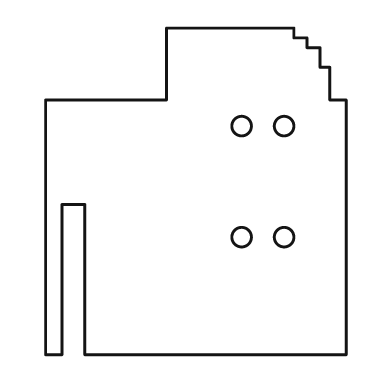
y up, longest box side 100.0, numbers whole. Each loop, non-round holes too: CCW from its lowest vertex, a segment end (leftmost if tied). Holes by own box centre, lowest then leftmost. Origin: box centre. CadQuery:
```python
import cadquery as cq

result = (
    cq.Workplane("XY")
    .moveTo(-46.0, -50.0)
    .lineTo(-41.0, -50.0)
    .lineTo(-41.0, -4.0)
    .lineTo(-34.0, -4.0)
    .lineTo(-34.0, -50.0)
    .lineTo(46.0, -50.0)
    .lineTo(46.0, 28.0)
    .lineTo(41.0, 28.0)
    .lineTo(41.0, 38.0)
    .lineTo(38.0, 38.0)
    .lineTo(38.0, 44.0)
    .lineTo(34.0, 44.0)
    .lineTo(34.0, 47.0)
    .lineTo(30.0, 47.0)
    .lineTo(30.0, 50.0)
    .lineTo(-9.0, 50.0)
    .lineTo(-9.0, 28.0)
    .lineTo(-46.0, 28.0)
    .close()
    .moveTo(14.0, -14.0)
    .circle(3.0)
    .moveTo(27.0, -14.0)
    .circle(3.0)
    .moveTo(14.0, 20.0)
    .circle(3.0)
    .moveTo(27.0, 20.0)
    .circle(3.0)
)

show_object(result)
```